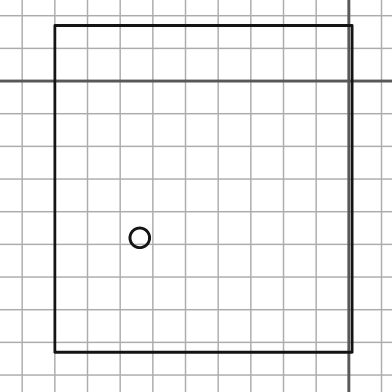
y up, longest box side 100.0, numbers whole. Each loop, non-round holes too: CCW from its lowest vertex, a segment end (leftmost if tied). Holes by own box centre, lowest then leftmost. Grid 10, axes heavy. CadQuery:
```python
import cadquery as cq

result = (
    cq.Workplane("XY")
    .moveTo(-90.0, -83.0)
    .lineTo(1.0, -83.0)
    .lineTo(1.0, 17.0)
    .lineTo(-90.0, 17.0)
    .close()
    .moveTo(-64.0, -48.0)
    .circle(3.0)
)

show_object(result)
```